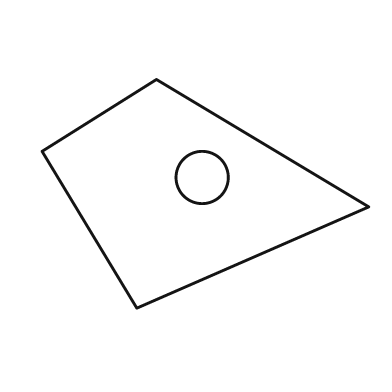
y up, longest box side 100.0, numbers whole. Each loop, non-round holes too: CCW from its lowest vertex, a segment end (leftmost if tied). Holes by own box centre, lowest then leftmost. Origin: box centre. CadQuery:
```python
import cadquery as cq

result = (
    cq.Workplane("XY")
    .moveTo(-21.0, -35.0)
    .lineTo(50.0, -4.0)
    .lineTo(-15.0, 35.0)
    .lineTo(-50.0, 13.0)
    .close()
    .moveTo(-1.0, 5.0)
    .circle(8.0)
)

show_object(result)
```